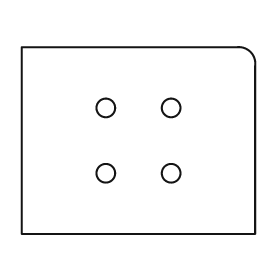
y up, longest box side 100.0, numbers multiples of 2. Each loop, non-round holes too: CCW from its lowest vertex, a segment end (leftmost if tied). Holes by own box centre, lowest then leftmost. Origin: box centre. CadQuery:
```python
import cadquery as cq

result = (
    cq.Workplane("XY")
    .moveTo(-50.0, -40.0)
    .lineTo(50.0, -40.0)
    .lineTo(50.0, 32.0)
    .threePointArc((48.0, 38.0), (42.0, 40.0))
    .lineTo(-50.0, 40.0)
    .close()
    .moveTo(-14.0, -14.0)
    .circle(4.0)
    .moveTo(14.0, -14.0)
    .circle(4.0)
    .moveTo(-14.0, 14.0)
    .circle(4.0)
    .moveTo(14.0, 14.0)
    .circle(4.0)
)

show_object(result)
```